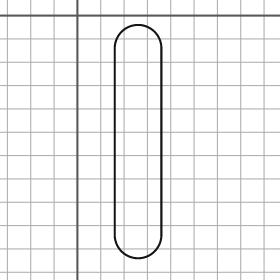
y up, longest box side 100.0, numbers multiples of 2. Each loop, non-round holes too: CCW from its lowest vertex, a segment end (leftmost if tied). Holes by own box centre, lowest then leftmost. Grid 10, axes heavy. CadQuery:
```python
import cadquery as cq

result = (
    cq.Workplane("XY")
    .moveTo(16.0, -94.0)
    .threePointArc((26.0, -104.0), (36.0, -94.0))
    .lineTo(36.0, -14.0)
    .threePointArc((26.0, -4.0), (16.0, -14.0))
    .close()
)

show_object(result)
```